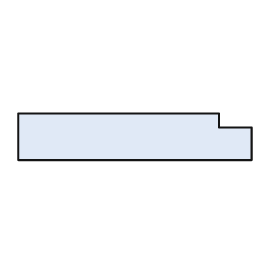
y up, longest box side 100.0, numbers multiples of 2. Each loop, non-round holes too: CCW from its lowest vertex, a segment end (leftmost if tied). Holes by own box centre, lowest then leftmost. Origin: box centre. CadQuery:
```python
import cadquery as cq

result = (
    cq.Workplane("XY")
    .moveTo(-50.0, -10.0)
    .lineTo(50.0, -10.0)
    .lineTo(50.0, 4.0)
    .lineTo(36.0, 4.0)
    .lineTo(36.0, 10.0)
    .lineTo(-50.0, 10.0)
    .close()
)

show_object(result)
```